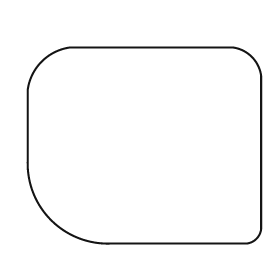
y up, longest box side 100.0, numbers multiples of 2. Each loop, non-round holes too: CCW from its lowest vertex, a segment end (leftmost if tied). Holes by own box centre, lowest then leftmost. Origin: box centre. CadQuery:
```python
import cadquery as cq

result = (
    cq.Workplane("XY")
    .moveTo(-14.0, -42.0)
    .lineTo(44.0, -42.0)
    .threePointArc((48.0, -40.0), (50.0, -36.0))
    .lineTo(50.0, 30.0)
    .threePointArc((46.0, 38.0), (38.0, 42.0))
    .lineTo(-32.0, 42.0)
    .threePointArc((-44.0, 36.0), (-50.0, 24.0))
    .lineTo(-50.0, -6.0)
    .threePointArc((-40.0, -32.0), (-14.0, -42.0))
    .close()
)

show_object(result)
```